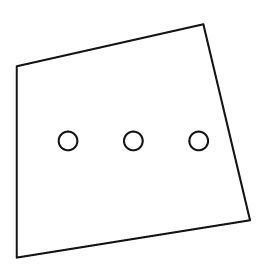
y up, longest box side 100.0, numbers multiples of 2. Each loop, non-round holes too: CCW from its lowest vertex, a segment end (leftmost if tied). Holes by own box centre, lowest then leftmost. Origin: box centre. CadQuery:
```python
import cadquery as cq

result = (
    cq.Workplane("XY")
    .moveTo(-50.0, -50.0)
    .lineTo(50.0, -34.0)
    .lineTo(30.0, 50.0)
    .lineTo(-50.0, 32.0)
    .close()
    .moveTo(-28.0, 0.0)
    .circle(4.0)
    .moveTo(0.0, 0.0)
    .circle(4.0)
    .moveTo(28.0, 0.0)
    .circle(4.0)
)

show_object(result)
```